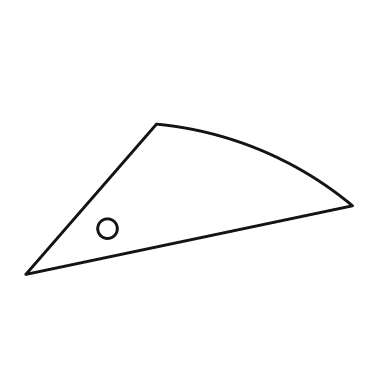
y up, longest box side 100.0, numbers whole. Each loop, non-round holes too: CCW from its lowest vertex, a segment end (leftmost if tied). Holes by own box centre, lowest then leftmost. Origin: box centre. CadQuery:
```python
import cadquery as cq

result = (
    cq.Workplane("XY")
    .moveTo(-50.0, -23.0)
    .lineTo(50.0, -2.0)
    .threePointArc((22.0, 15.0), (-10.0, 23.0))
    .close()
    .moveTo(-25.0, -9.0)
    .circle(3.0)
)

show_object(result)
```